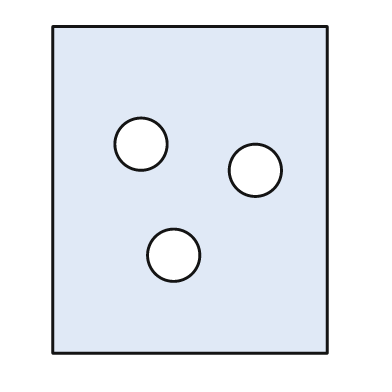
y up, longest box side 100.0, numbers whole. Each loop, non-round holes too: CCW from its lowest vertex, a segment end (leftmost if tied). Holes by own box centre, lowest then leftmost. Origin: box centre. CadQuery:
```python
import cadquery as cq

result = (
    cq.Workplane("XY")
    .moveTo(-42.0, -50.0)
    .lineTo(42.0, -50.0)
    .lineTo(42.0, 50.0)
    .lineTo(-42.0, 50.0)
    .close()
    .moveTo(-5.0, -20.0)
    .circle(8.0)
    .moveTo(20.0, 6.0)
    .circle(8.0)
    .moveTo(-15.0, 14.0)
    .circle(8.0)
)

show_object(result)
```